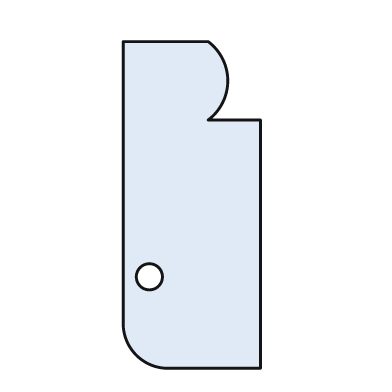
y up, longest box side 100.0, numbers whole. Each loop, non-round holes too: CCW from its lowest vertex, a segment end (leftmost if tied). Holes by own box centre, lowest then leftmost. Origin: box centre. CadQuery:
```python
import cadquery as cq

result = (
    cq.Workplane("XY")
    .moveTo(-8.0, -50.0)
    .lineTo(21.0, -50.0)
    .lineTo(21.0, 26.0)
    .lineTo(5.0, 26.0)
    .threePointArc((11.0, 38.0), (5.0, 50.0))
    .lineTo(-21.0, 50.0)
    .lineTo(-21.0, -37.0)
    .threePointArc((-17.0, -46.0), (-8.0, -50.0))
    .close()
    .moveTo(-13.0, -22.0)
    .circle(4.0)
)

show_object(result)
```